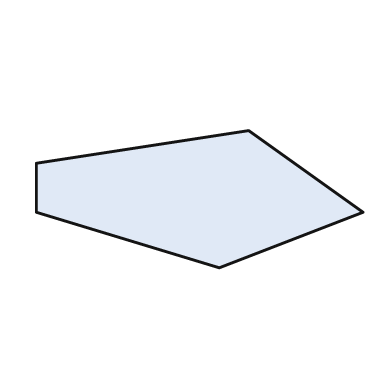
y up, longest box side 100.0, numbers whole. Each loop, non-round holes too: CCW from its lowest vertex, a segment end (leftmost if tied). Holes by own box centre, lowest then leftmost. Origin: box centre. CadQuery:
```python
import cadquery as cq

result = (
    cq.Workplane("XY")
    .moveTo(6.0, -21.0)
    .lineTo(50.0, -4.0)
    .lineTo(15.0, 21.0)
    .lineTo(-50.0, 11.0)
    .lineTo(-50.0, -4.0)
    .close()
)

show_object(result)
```